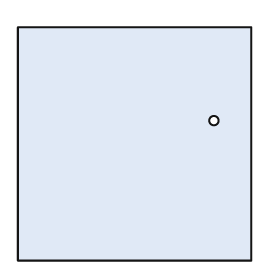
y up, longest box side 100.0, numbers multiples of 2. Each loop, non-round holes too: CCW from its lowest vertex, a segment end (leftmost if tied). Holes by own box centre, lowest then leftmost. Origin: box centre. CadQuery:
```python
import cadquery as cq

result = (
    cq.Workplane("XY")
    .moveTo(-50.0, -50.0)
    .lineTo(50.0, -50.0)
    .lineTo(50.0, 50.0)
    .lineTo(-50.0, 50.0)
    .close()
    .moveTo(34.0, 10.0)
    .circle(2.0)
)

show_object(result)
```